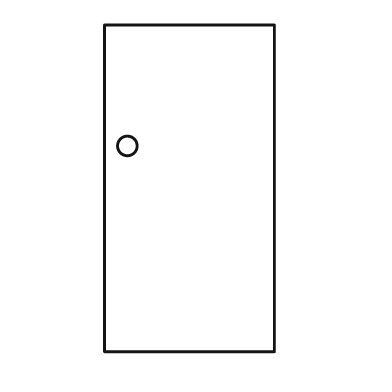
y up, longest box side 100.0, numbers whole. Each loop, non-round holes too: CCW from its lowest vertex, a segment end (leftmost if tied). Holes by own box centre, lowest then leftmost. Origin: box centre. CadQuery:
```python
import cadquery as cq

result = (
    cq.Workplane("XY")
    .moveTo(-26.0, -50.0)
    .lineTo(26.0, -50.0)
    .lineTo(26.0, 50.0)
    .lineTo(-26.0, 50.0)
    .close()
    .moveTo(-19.0, 13.0)
    .circle(3.0)
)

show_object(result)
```